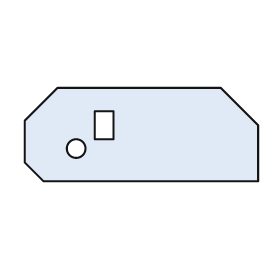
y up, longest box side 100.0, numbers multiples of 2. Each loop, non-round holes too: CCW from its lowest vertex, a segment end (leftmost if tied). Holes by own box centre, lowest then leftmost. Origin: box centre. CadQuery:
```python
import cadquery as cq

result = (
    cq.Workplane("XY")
    .moveTo(-42.0, -20.0)
    .lineTo(50.0, -20.0)
    .lineTo(50.0, 4.0)
    .lineTo(34.0, 20.0)
    .lineTo(-36.0, 20.0)
    .lineTo(-50.0, 6.0)
    .lineTo(-50.0, -12.0)
    .close()
    .moveTo(-28.0, -6.0)
    .circle(4.0)
    .moveTo(-20.0, -2.0)
    .lineTo(-12.0, -2.0)
    .lineTo(-12.0, 10.0)
    .lineTo(-20.0, 10.0)
    .close()
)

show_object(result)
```